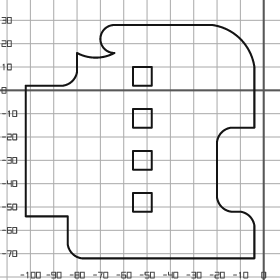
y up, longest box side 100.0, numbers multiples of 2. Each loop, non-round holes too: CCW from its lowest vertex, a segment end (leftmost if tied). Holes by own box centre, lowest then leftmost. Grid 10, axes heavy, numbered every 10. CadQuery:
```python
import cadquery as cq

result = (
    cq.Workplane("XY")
    .moveTo(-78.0, -72.0)
    .lineTo(-4.0, -72.0)
    .lineTo(-4.0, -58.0)
    .threePointArc((-6.0, -54.0), (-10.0, -52.0))
    .lineTo(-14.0, -52.0)
    .threePointArc((-18.0, -50.0), (-20.0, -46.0))
    .lineTo(-20.0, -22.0)
    .threePointArc((-18.0, -18.0), (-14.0, -16.0))
    .lineTo(-4.0, -16.0)
    .lineTo(-4.0, 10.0)
    .threePointArc((-10.0, 22.0), (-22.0, 28.0))
    .lineTo(-64.0, 28.0)
    .threePointArc((-70.0, 22.0), (-64.0, 16.0))
    .threePointArc((-72.0, 14.0), (-80.0, 16.0))
    .lineTo(-80.0, 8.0)
    .threePointArc((-82.0, 4.0), (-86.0, 2.0))
    .lineTo(-102.0, 2.0)
    .lineTo(-102.0, -54.0)
    .lineTo(-84.0, -54.0)
    .lineTo(-84.0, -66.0)
    .threePointArc((-82.0, -70.0), (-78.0, -72.0))
    .close()
    .moveTo(-56.0, -52.0)
    .lineTo(-48.0, -52.0)
    .lineTo(-48.0, -44.0)
    .lineTo(-56.0, -44.0)
    .close()
    .moveTo(-56.0, -34.0)
    .lineTo(-48.0, -34.0)
    .lineTo(-48.0, -26.0)
    .lineTo(-56.0, -26.0)
    .close()
    .moveTo(-56.0, -16.0)
    .lineTo(-48.0, -16.0)
    .lineTo(-48.0, -8.0)
    .lineTo(-56.0, -8.0)
    .close()
    .moveTo(-56.0, 2.0)
    .lineTo(-48.0, 2.0)
    .lineTo(-48.0, 10.0)
    .lineTo(-56.0, 10.0)
    .close()
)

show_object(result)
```